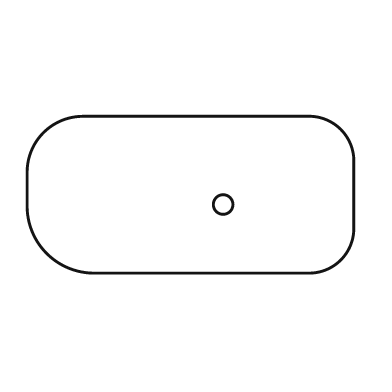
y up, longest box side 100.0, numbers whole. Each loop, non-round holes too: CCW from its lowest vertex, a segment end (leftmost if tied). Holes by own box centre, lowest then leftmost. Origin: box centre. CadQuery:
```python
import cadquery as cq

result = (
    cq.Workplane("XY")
    .moveTo(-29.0, -24.0)
    .lineTo(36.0, -24.0)
    .threePointArc((46.0, -20.0), (50.0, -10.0))
    .lineTo(50.0, 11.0)
    .threePointArc((46.0, 20.0), (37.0, 24.0))
    .lineTo(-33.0, 24.0)
    .threePointArc((-45.0, 19.0), (-50.0, 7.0))
    .lineTo(-50.0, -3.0)
    .threePointArc((-44.0, -18.0), (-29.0, -24.0))
    .close()
    .moveTo(10.0, -3.0)
    .circle(3.0)
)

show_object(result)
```